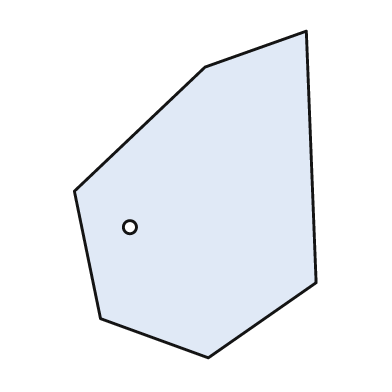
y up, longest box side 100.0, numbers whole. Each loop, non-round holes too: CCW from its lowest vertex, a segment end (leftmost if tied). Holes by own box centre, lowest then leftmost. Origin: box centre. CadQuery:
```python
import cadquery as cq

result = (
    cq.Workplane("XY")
    .moveTo(4.0, -50.0)
    .lineTo(37.0, -27.0)
    .lineTo(34.0, 50.0)
    .lineTo(3.0, 39.0)
    .lineTo(-37.0, 1.0)
    .lineTo(-29.0, -38.0)
    .close()
    .moveTo(-20.0, -10.0)
    .circle(2.0)
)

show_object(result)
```